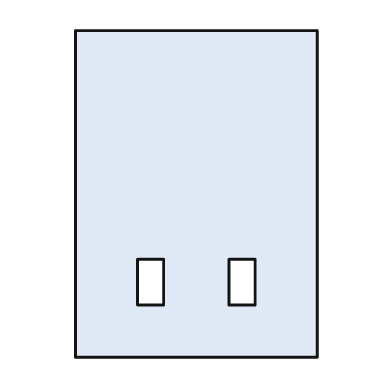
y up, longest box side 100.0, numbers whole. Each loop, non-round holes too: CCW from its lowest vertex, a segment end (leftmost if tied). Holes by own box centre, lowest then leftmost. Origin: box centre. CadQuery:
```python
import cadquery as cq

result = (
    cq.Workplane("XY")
    .moveTo(-37.0, -50.0)
    .lineTo(37.0, -50.0)
    .lineTo(37.0, 50.0)
    .lineTo(-37.0, 50.0)
    .close()
    .moveTo(-18.0, -34.0)
    .lineTo(-10.0, -34.0)
    .lineTo(-10.0, -20.0)
    .lineTo(-18.0, -20.0)
    .close()
    .moveTo(10.0, -34.0)
    .lineTo(18.0, -34.0)
    .lineTo(18.0, -20.0)
    .lineTo(10.0, -20.0)
    .close()
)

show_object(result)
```